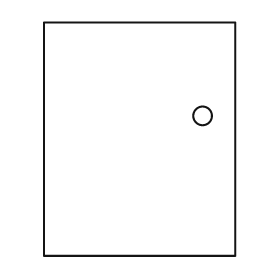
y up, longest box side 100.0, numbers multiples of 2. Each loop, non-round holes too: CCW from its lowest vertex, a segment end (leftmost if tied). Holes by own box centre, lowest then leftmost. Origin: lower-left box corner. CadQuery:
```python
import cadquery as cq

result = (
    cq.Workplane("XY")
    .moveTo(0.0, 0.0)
    .lineTo(82.0, 0.0)
    .lineTo(82.0, 100.0)
    .lineTo(0.0, 100.0)
    .close()
    .moveTo(68.0, 60.0)
    .circle(4.0)
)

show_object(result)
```